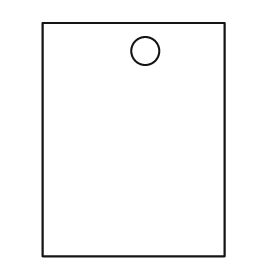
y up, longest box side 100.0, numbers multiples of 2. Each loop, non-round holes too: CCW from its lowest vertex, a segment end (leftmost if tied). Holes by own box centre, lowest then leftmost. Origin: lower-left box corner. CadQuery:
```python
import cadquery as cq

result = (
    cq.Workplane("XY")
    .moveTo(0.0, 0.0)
    .lineTo(78.0, 0.0)
    .lineTo(78.0, 100.0)
    .lineTo(0.0, 100.0)
    .close()
    .moveTo(44.0, 88.0)
    .circle(6.0)
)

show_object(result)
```